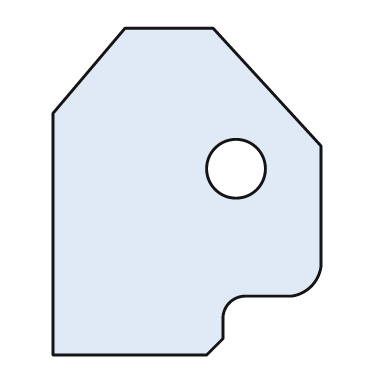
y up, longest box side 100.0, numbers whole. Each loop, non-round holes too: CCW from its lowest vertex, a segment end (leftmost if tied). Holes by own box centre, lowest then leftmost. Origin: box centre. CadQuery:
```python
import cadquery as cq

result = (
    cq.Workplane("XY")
    .moveTo(-41.0, -50.0)
    .lineTo(6.0, -50.0)
    .lineTo(11.0, -45.0)
    .lineTo(11.0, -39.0)
    .threePointArc((13.0, -34.0), (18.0, -32.0))
    .lineTo(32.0, -32.0)
    .threePointArc((38.0, -29.0), (41.0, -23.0))
    .lineTo(41.0, 14.0)
    .lineTo(8.0, 50.0)
    .lineTo(-19.0, 50.0)
    .lineTo(-41.0, 24.0)
    .close()
    .moveTo(15.0, 7.0)
    .circle(9.0)
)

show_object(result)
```